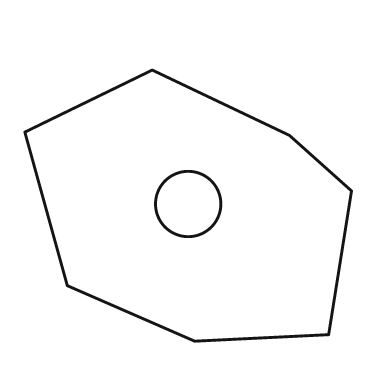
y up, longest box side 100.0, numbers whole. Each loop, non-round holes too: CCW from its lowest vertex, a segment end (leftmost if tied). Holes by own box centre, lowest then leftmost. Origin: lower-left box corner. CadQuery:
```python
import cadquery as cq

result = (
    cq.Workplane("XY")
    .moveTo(52.0, 0.0)
    .lineTo(93.0, 2.0)
    .lineTo(100.0, 46.0)
    .lineTo(81.0, 63.0)
    .lineTo(39.0, 83.0)
    .lineTo(0.0, 64.0)
    .lineTo(13.0, 17.0)
    .close()
    .moveTo(50.0, 42.0)
    .circle(10.0)
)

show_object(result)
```